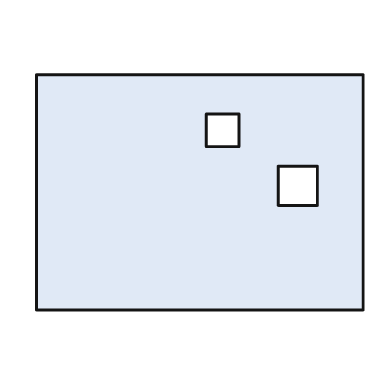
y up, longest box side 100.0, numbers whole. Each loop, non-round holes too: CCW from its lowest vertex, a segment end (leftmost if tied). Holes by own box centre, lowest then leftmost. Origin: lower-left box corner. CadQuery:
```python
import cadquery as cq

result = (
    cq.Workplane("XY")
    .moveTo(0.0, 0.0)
    .lineTo(100.0, 0.0)
    .lineTo(100.0, 72.0)
    .lineTo(0.0, 72.0)
    .close()
    .moveTo(74.0, 32.0)
    .lineTo(86.0, 32.0)
    .lineTo(86.0, 44.0)
    .lineTo(74.0, 44.0)
    .close()
    .moveTo(52.0, 50.0)
    .lineTo(62.0, 50.0)
    .lineTo(62.0, 60.0)
    .lineTo(52.0, 60.0)
    .close()
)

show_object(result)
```